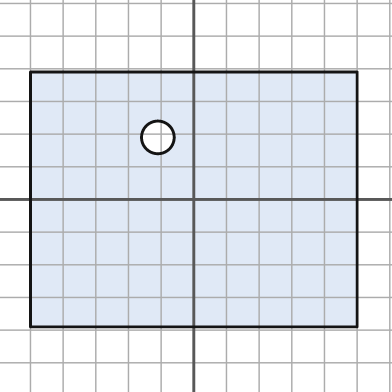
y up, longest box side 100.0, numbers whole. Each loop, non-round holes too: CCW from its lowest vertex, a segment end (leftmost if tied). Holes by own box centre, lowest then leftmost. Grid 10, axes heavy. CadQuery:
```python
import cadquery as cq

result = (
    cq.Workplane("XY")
    .moveTo(-50.0, -39.0)
    .lineTo(50.0, -39.0)
    .lineTo(50.0, 39.0)
    .lineTo(-50.0, 39.0)
    .close()
    .moveTo(-11.0, 19.0)
    .circle(5.0)
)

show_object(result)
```